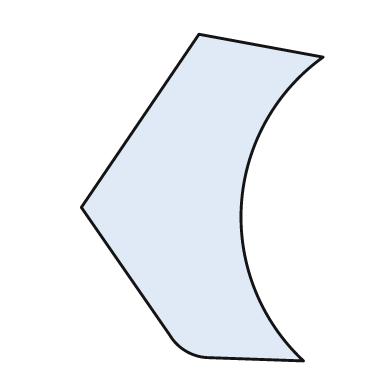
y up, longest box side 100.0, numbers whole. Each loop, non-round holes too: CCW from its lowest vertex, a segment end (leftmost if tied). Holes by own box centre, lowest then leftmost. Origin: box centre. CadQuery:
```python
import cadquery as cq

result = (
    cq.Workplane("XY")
    .moveTo(31.0, -50.0)
    .threePointArc((12.0, -2.0), (37.0, 43.0))
    .lineTo(-1.0, 50.0)
    .lineTo(-37.0, -3.0)
    .lineTo(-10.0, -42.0)
    .threePointArc((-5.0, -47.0), (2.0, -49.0))
    .close()
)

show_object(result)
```